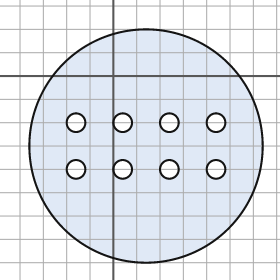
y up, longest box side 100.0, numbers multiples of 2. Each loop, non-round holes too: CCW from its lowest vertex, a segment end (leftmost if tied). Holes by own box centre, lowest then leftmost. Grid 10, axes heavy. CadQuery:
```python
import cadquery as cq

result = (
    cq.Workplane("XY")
    .moveTo(14.0, -30.0)
    .circle(50.0)
    .moveTo(-16.0, -40.0)
    .circle(4.0)
    .moveTo(4.0, -40.0)
    .circle(4.0)
    .moveTo(24.0, -40.0)
    .circle(4.0)
    .moveTo(44.0, -40.0)
    .circle(4.0)
    .moveTo(-16.0, -20.0)
    .circle(4.0)
    .moveTo(4.0, -20.0)
    .circle(4.0)
    .moveTo(24.0, -20.0)
    .circle(4.0)
    .moveTo(44.0, -20.0)
    .circle(4.0)
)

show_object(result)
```